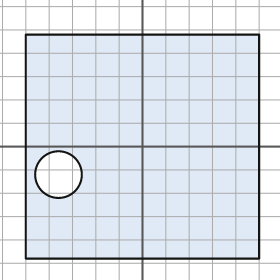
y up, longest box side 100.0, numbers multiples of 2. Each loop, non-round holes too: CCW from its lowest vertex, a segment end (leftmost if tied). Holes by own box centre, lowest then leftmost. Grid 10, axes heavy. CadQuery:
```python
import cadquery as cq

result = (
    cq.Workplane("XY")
    .moveTo(-50.0, -48.0)
    .lineTo(50.0, -48.0)
    .lineTo(50.0, 48.0)
    .lineTo(-50.0, 48.0)
    .close()
    .moveTo(-36.0, -12.0)
    .circle(10.0)
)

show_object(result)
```